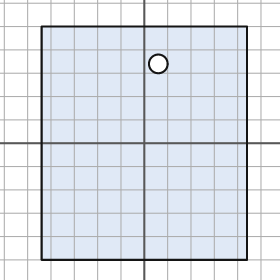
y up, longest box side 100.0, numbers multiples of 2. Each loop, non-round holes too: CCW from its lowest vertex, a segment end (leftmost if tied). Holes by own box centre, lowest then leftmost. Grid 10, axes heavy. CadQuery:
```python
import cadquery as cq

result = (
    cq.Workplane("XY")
    .moveTo(-44.0, -50.0)
    .lineTo(44.0, -50.0)
    .lineTo(44.0, 50.0)
    .lineTo(-44.0, 50.0)
    .close()
    .moveTo(6.0, 34.0)
    .circle(4.0)
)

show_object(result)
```